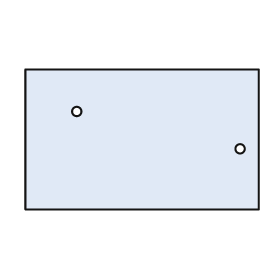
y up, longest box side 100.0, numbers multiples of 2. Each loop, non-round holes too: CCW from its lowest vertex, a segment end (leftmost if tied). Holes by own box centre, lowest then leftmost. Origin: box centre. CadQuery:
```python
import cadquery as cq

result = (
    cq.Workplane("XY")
    .moveTo(-50.0, -30.0)
    .lineTo(50.0, -30.0)
    .lineTo(50.0, 30.0)
    .lineTo(-50.0, 30.0)
    .close()
    .moveTo(42.0, -4.0)
    .circle(2.0)
    .moveTo(-28.0, 12.0)
    .circle(2.0)
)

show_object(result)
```